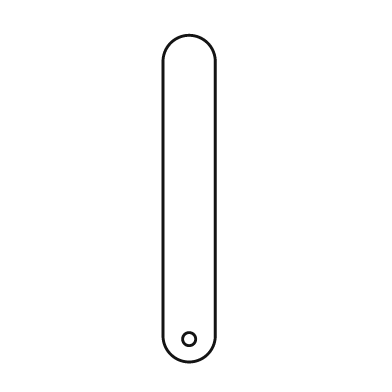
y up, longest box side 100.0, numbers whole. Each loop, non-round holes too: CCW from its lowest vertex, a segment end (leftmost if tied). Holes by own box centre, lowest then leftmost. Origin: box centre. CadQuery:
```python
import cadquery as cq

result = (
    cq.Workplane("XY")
    .moveTo(-8.0, -42.0)
    .threePointArc((0.0, -50.0), (8.0, -42.0))
    .lineTo(8.0, 42.0)
    .threePointArc((0.0, 50.0), (-8.0, 42.0))
    .close()
    .moveTo(0.0, -43.0)
    .circle(2.0)
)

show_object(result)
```